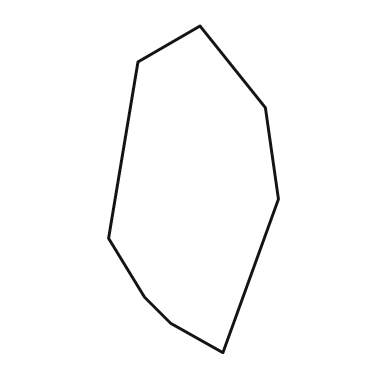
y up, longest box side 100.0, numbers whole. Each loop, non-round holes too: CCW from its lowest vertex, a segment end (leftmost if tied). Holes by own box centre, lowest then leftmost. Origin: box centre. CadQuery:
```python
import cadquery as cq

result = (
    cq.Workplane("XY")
    .moveTo(9.0, -50.0)
    .lineTo(26.0, -3.0)
    .lineTo(22.0, 25.0)
    .lineTo(2.0, 50.0)
    .lineTo(-17.0, 39.0)
    .lineTo(-26.0, -15.0)
    .lineTo(-15.0, -33.0)
    .lineTo(-7.0, -41.0)
    .close()
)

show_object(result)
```